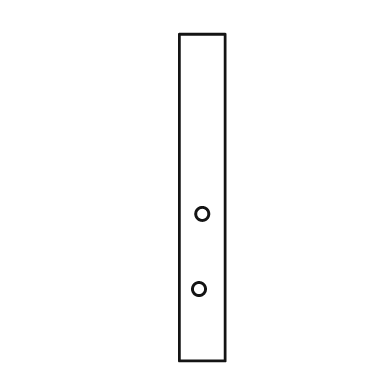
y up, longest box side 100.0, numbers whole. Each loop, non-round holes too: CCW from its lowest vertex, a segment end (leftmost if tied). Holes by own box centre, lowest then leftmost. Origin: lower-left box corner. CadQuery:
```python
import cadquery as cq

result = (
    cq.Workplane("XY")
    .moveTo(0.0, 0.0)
    .lineTo(14.0, 0.0)
    .lineTo(14.0, 100.0)
    .lineTo(0.0, 100.0)
    .close()
    .moveTo(6.0, 22.0)
    .circle(2.0)
    .moveTo(7.0, 45.0)
    .circle(2.0)
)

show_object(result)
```